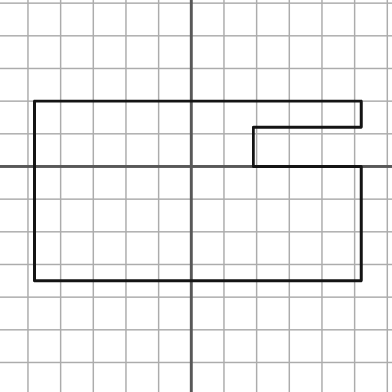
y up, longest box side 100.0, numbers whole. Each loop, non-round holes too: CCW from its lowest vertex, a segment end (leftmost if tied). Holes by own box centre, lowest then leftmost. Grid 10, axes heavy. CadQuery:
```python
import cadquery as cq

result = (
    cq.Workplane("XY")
    .moveTo(-48.0, -35.0)
    .lineTo(52.0, -35.0)
    .lineTo(52.0, 0.0)
    .lineTo(19.0, 0.0)
    .lineTo(19.0, 12.0)
    .lineTo(52.0, 12.0)
    .lineTo(52.0, 20.0)
    .lineTo(-48.0, 20.0)
    .close()
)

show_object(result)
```